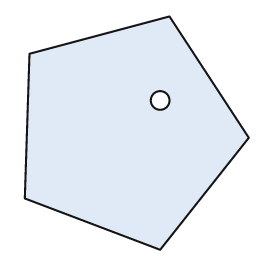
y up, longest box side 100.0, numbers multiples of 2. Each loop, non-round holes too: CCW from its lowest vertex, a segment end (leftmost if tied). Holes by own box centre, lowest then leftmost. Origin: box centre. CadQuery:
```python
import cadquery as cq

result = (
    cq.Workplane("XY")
    .moveTo(10.0, -50.0)
    .lineTo(48.0, -2.0)
    .lineTo(14.0, 50.0)
    .lineTo(-46.0, 34.0)
    .lineTo(-48.0, -28.0)
    .close()
    .moveTo(10.0, 14.0)
    .circle(4.0)
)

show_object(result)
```